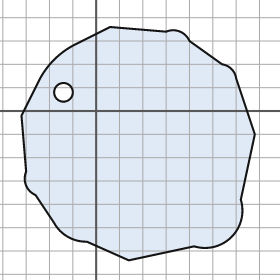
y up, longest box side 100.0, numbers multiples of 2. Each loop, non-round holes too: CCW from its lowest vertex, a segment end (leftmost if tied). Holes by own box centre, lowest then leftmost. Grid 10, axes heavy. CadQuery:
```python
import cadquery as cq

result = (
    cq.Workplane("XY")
    .moveTo(14.0, -64.0)
    .lineTo(42.0, -58.0)
    .threePointArc((58.0, -54.0), (62.0, -38.0))
    .lineTo(68.0, -10.0)
    .lineTo(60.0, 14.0)
    .threePointArc((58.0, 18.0), (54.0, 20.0))
    .lineTo(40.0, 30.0)
    .threePointArc((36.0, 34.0), (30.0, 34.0))
    .lineTo(6.0, 36.0)
    .lineTo(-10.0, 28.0)
    .threePointArc((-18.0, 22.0), (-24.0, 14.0))
    .lineTo(-32.0, -2.0)
    .lineTo(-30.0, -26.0)
    .threePointArc((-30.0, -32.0), (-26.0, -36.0))
    .lineTo(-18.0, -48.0)
    .threePointArc((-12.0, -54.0), (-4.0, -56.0))
    .close()
    .moveTo(-14.0, 8.0)
    .circle(4.0)
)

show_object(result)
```